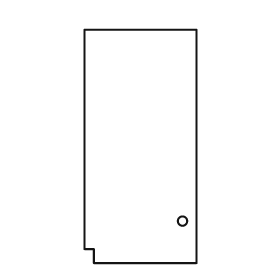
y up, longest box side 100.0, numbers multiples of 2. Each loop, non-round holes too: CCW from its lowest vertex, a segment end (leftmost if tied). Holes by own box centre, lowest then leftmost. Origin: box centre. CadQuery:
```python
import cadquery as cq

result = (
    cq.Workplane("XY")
    .moveTo(-20.0, -50.0)
    .lineTo(24.0, -50.0)
    .lineTo(24.0, 50.0)
    .lineTo(-24.0, 50.0)
    .lineTo(-24.0, -44.0)
    .lineTo(-20.0, -44.0)
    .close()
    .moveTo(18.0, -32.0)
    .circle(2.0)
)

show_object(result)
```